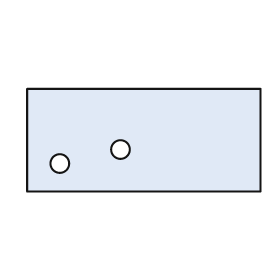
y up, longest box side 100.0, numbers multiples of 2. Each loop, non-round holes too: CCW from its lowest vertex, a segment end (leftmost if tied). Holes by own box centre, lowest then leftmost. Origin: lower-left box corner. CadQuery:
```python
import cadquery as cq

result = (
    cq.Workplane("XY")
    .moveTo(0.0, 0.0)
    .lineTo(100.0, 0.0)
    .lineTo(100.0, 44.0)
    .lineTo(0.0, 44.0)
    .close()
    .moveTo(14.0, 12.0)
    .circle(4.0)
    .moveTo(40.0, 18.0)
    .circle(4.0)
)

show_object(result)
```